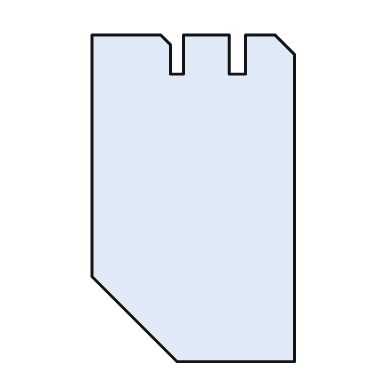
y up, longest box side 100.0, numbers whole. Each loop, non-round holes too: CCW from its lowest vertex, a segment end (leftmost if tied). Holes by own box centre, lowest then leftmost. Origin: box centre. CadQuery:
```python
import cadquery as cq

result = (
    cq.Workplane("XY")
    .moveTo(-5.0, -50.0)
    .lineTo(31.0, -50.0)
    .lineTo(31.0, 44.0)
    .lineTo(25.0, 50.0)
    .lineTo(16.0, 50.0)
    .lineTo(16.0, 38.0)
    .lineTo(11.0, 38.0)
    .lineTo(11.0, 50.0)
    .lineTo(-3.0, 50.0)
    .lineTo(-3.0, 38.0)
    .lineTo(-7.0, 38.0)
    .lineTo(-7.0, 47.0)
    .lineTo(-10.0, 50.0)
    .lineTo(-31.0, 50.0)
    .lineTo(-31.0, -24.0)
    .close()
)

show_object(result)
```